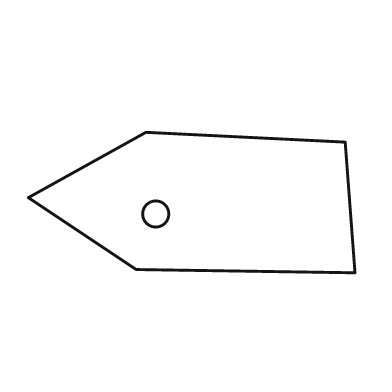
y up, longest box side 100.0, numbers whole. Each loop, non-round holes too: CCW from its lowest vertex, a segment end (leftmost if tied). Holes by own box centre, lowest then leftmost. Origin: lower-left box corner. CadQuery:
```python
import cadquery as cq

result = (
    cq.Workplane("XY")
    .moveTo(100.0, 0.0)
    .lineTo(97.0, 40.0)
    .lineTo(36.0, 43.0)
    .lineTo(0.0, 23.0)
    .lineTo(33.0, 1.0)
    .close()
    .moveTo(39.0, 18.0)
    .circle(4.0)
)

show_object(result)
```